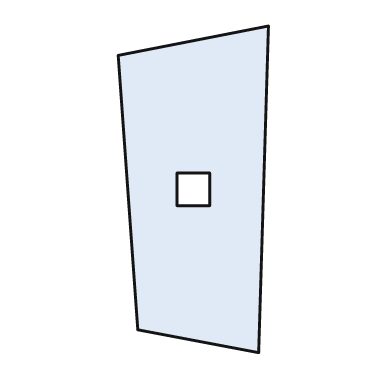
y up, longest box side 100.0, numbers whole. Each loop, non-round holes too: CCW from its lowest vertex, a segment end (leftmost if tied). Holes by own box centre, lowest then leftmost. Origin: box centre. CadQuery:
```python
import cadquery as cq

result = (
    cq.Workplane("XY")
    .moveTo(20.0, -50.0)
    .lineTo(23.0, 50.0)
    .lineTo(-23.0, 41.0)
    .lineTo(-17.0, -43.0)
    .close()
    .moveTo(-5.0, -5.0)
    .lineTo(5.0, -5.0)
    .lineTo(5.0, 5.0)
    .lineTo(-5.0, 5.0)
    .close()
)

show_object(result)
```